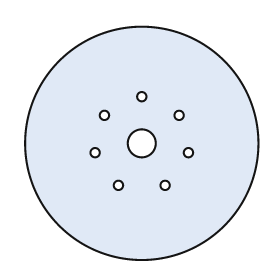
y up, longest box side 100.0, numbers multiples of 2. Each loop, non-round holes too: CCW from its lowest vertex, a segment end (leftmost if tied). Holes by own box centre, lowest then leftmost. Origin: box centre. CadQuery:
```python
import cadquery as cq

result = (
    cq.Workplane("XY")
    .moveTo(0.0, 0.0)
    .circle(50.0)
    .moveTo(-10.0, -18.0)
    .circle(2.0)
    .moveTo(10.0, -18.0)
    .circle(2.0)
    .moveTo(-20.0, -4.0)
    .circle(2.0)
    .moveTo(20.0, -4.0)
    .circle(2.0)
    .moveTo(0.0, 0.0)
    .circle(6.0)
    .moveTo(-16.0, 12.0)
    .circle(2.0)
    .moveTo(16.0, 12.0)
    .circle(2.0)
    .moveTo(0.0, 20.0)
    .circle(2.0)
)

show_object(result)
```